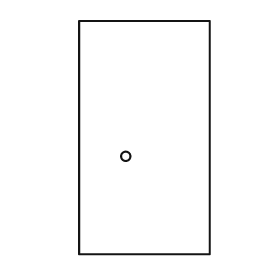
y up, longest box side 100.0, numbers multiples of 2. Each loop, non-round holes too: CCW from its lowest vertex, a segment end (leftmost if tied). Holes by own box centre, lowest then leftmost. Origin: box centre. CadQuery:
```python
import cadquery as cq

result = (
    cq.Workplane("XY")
    .moveTo(-28.0, -50.0)
    .lineTo(28.0, -50.0)
    .lineTo(28.0, 50.0)
    .lineTo(-28.0, 50.0)
    .close()
    .moveTo(-8.0, -8.0)
    .circle(2.0)
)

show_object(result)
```